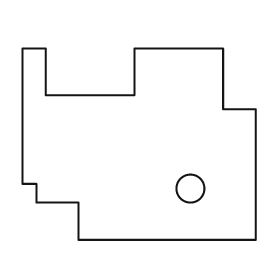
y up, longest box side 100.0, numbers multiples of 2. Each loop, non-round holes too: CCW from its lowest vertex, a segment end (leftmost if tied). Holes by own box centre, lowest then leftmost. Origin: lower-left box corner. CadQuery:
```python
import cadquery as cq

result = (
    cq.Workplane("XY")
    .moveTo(24.0, 0.0)
    .lineTo(100.0, 0.0)
    .lineTo(100.0, 56.0)
    .lineTo(86.0, 56.0)
    .lineTo(86.0, 82.0)
    .lineTo(48.0, 82.0)
    .lineTo(48.0, 62.0)
    .lineTo(10.0, 62.0)
    .lineTo(10.0, 82.0)
    .lineTo(0.0, 82.0)
    .lineTo(0.0, 24.0)
    .lineTo(6.0, 24.0)
    .lineTo(6.0, 16.0)
    .lineTo(24.0, 16.0)
    .close()
    .moveTo(72.0, 22.0)
    .circle(6.0)
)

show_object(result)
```